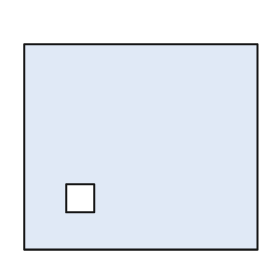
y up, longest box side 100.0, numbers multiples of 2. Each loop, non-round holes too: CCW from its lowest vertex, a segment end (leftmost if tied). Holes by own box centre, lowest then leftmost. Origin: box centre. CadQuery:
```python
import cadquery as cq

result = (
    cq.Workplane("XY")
    .moveTo(-50.0, -44.0)
    .lineTo(50.0, -44.0)
    .lineTo(50.0, 44.0)
    .lineTo(-50.0, 44.0)
    .close()
    .moveTo(-32.0, -28.0)
    .lineTo(-20.0, -28.0)
    .lineTo(-20.0, -16.0)
    .lineTo(-32.0, -16.0)
    .close()
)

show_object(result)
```